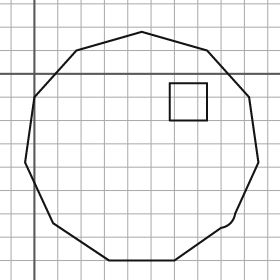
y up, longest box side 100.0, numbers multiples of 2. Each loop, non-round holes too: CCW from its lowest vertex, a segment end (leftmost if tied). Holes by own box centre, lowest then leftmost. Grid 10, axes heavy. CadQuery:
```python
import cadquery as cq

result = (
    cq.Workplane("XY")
    .moveTo(32.0, -80.0)
    .lineTo(60.0, -80.0)
    .lineTo(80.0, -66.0)
    .threePointArc((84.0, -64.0), (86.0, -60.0))
    .lineTo(96.0, -38.0)
    .lineTo(92.0, -10.0)
    .lineTo(74.0, 10.0)
    .lineTo(46.0, 18.0)
    .lineTo(18.0, 10.0)
    .lineTo(0.0, -10.0)
    .lineTo(-4.0, -38.0)
    .lineTo(8.0, -64.0)
    .close()
    .moveTo(58.0, -20.0)
    .lineTo(74.0, -20.0)
    .lineTo(74.0, -4.0)
    .lineTo(58.0, -4.0)
    .close()
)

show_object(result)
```